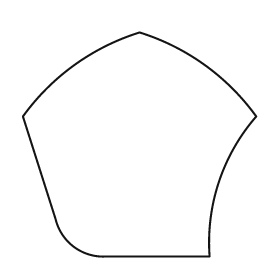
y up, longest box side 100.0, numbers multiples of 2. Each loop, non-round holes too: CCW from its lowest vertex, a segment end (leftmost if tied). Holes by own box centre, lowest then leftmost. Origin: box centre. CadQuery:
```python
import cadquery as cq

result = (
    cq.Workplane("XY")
    .moveTo(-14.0, -48.0)
    .lineTo(30.0, -48.0)
    .threePointArc((34.0, -16.0), (50.0, 12.0))
    .threePointArc((28.0, 34.0), (0.0, 48.0))
    .threePointArc((-28.0, 34.0), (-50.0, 12.0))
    .lineTo(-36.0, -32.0)
    .threePointArc((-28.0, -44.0), (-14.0, -48.0))
    .close()
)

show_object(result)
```